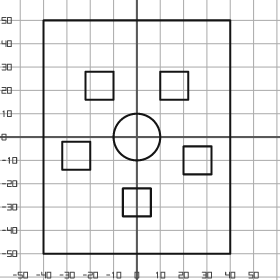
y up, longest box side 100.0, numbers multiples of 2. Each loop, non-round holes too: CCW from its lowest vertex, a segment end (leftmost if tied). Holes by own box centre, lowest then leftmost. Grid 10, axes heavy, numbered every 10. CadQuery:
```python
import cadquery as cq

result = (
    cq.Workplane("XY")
    .moveTo(-40.0, -50.0)
    .lineTo(40.0, -50.0)
    .lineTo(40.0, 50.0)
    .lineTo(-40.0, 50.0)
    .close()
    .moveTo(-6.0, -34.0)
    .lineTo(6.0, -34.0)
    .lineTo(6.0, -22.0)
    .lineTo(-6.0, -22.0)
    .close()
    .moveTo(20.0, -16.0)
    .lineTo(32.0, -16.0)
    .lineTo(32.0, -4.0)
    .lineTo(20.0, -4.0)
    .close()
    .moveTo(-32.0, -14.0)
    .lineTo(-20.0, -14.0)
    .lineTo(-20.0, -2.0)
    .lineTo(-32.0, -2.0)
    .close()
    .moveTo(0.0, 0.0)
    .circle(10.0)
    .moveTo(-22.0, 16.0)
    .lineTo(-10.0, 16.0)
    .lineTo(-10.0, 28.0)
    .lineTo(-22.0, 28.0)
    .close()
    .moveTo(10.0, 16.0)
    .lineTo(22.0, 16.0)
    .lineTo(22.0, 28.0)
    .lineTo(10.0, 28.0)
    .close()
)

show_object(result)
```